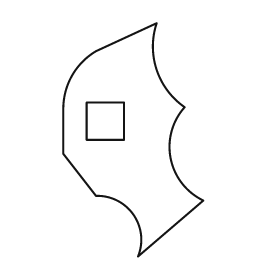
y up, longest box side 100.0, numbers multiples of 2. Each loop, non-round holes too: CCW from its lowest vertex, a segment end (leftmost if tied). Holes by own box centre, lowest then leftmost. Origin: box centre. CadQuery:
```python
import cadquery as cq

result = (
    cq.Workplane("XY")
    .moveTo(2.0, -50.0)
    .lineTo(30.0, -26.0)
    .threePointArc((16.0, -8.0), (22.0, 14.0))
    .threePointArc((10.0, 30.0), (10.0, 50.0))
    .lineTo(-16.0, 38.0)
    .threePointArc((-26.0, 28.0), (-30.0, 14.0))
    .lineTo(-30.0, -6.0)
    .lineTo(-16.0, -24.0)
    .threePointArc((0.0, -32.0), (2.0, -50.0))
    .close()
    .moveTo(-20.0, 0.0)
    .lineTo(-4.0, 0.0)
    .lineTo(-4.0, 16.0)
    .lineTo(-20.0, 16.0)
    .close()
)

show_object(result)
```